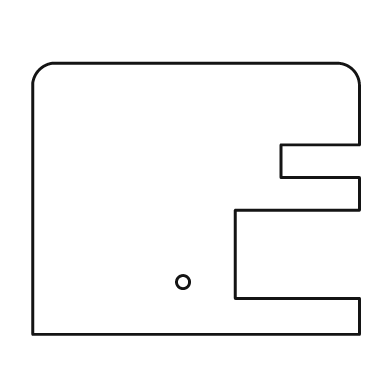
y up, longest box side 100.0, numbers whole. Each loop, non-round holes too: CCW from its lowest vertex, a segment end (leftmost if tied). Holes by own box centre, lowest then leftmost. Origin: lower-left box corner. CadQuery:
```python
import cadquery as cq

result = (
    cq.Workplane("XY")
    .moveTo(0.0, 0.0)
    .lineTo(100.0, 0.0)
    .lineTo(100.0, 11.0)
    .lineTo(62.0, 11.0)
    .lineTo(62.0, 38.0)
    .lineTo(100.0, 38.0)
    .lineTo(100.0, 48.0)
    .lineTo(76.0, 48.0)
    .lineTo(76.0, 58.0)
    .lineTo(100.0, 58.0)
    .lineTo(100.0, 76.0)
    .threePointArc((98.0, 81.0), (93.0, 83.0))
    .lineTo(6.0, 83.0)
    .threePointArc((2.0, 81.0), (0.0, 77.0))
    .close()
    .moveTo(46.0, 16.0)
    .circle(2.0)
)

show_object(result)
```